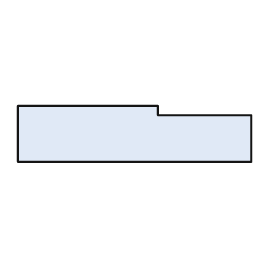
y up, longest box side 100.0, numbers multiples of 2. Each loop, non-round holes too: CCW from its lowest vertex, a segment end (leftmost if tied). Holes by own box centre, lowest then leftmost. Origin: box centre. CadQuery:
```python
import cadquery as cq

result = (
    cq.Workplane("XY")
    .moveTo(-50.0, -12.0)
    .lineTo(50.0, -12.0)
    .lineTo(50.0, 8.0)
    .lineTo(10.0, 8.0)
    .lineTo(10.0, 12.0)
    .lineTo(-50.0, 12.0)
    .close()
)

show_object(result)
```